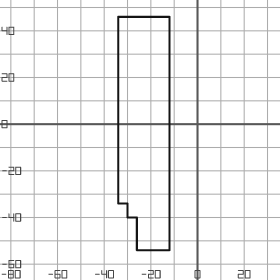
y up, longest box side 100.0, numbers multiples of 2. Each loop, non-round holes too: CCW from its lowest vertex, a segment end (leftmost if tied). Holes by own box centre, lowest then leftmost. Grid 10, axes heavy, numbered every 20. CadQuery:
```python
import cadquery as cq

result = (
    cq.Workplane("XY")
    .moveTo(-26.0, -54.0)
    .lineTo(-12.0, -54.0)
    .lineTo(-12.0, 46.0)
    .lineTo(-34.0, 46.0)
    .lineTo(-34.0, -34.0)
    .lineTo(-30.0, -34.0)
    .lineTo(-30.0, -40.0)
    .lineTo(-26.0, -40.0)
    .close()
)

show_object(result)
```